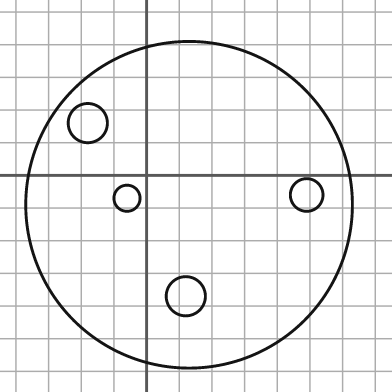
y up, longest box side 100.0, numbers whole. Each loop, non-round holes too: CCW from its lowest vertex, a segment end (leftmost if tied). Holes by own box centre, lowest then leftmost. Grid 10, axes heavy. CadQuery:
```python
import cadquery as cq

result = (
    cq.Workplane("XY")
    .moveTo(13.0, -9.0)
    .circle(50.0)
    .moveTo(12.0, -37.0)
    .circle(6.0)
    .moveTo(-6.0, -7.0)
    .circle(4.0)
    .moveTo(49.0, -6.0)
    .circle(5.0)
    .moveTo(-18.0, 16.0)
    .circle(6.0)
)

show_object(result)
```